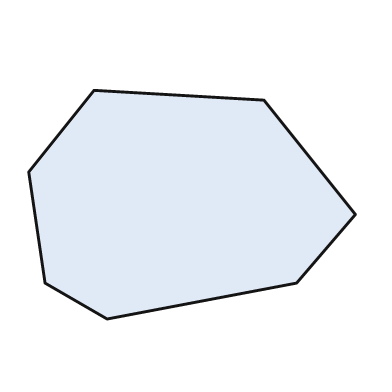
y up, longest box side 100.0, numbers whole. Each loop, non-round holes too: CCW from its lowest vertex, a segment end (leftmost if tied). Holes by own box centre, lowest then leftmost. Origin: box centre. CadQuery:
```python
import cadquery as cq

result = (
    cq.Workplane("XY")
    .moveTo(-26.0, -35.0)
    .lineTo(32.0, -24.0)
    .lineTo(50.0, -3.0)
    .lineTo(22.0, 32.0)
    .lineTo(-30.0, 35.0)
    .lineTo(-50.0, 10.0)
    .lineTo(-45.0, -24.0)
    .close()
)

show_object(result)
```